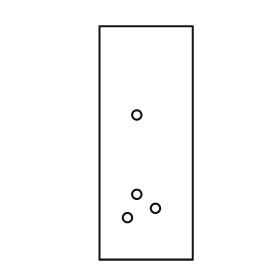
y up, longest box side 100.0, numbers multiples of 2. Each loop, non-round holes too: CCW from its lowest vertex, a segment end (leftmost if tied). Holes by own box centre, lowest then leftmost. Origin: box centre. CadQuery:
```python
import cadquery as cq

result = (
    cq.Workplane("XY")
    .moveTo(-20.0, -50.0)
    .lineTo(20.0, -50.0)
    .lineTo(20.0, 50.0)
    .lineTo(-20.0, 50.0)
    .close()
    .moveTo(-8.0, -32.0)
    .circle(2.0)
    .moveTo(4.0, -28.0)
    .circle(2.0)
    .moveTo(-4.0, -22.0)
    .circle(2.0)
    .moveTo(-4.0, 12.0)
    .circle(2.0)
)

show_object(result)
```